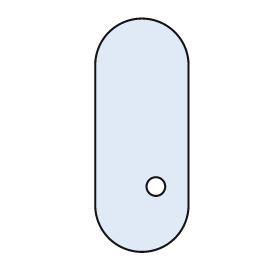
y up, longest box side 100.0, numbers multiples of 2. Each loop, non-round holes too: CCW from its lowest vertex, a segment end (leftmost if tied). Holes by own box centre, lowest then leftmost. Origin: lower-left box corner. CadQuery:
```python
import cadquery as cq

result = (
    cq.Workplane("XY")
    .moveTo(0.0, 20.0)
    .threePointArc((20.0, 0.0), (40.0, 20.0))
    .lineTo(40.0, 80.0)
    .threePointArc((20.0, 100.0), (0.0, 80.0))
    .close()
    .moveTo(26.0, 28.0)
    .circle(4.0)
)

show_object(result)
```